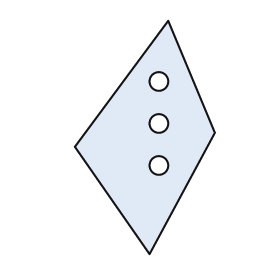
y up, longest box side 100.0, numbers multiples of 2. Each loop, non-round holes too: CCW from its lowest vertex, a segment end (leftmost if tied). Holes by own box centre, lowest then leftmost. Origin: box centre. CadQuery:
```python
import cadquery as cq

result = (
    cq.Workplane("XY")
    .moveTo(2.0, -50.0)
    .lineTo(30.0, 2.0)
    .lineTo(10.0, 50.0)
    .lineTo(-30.0, -4.0)
    .close()
    .moveTo(6.0, -12.0)
    .circle(4.0)
    .moveTo(6.0, 6.0)
    .circle(4.0)
    .moveTo(6.0, 24.0)
    .circle(4.0)
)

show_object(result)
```